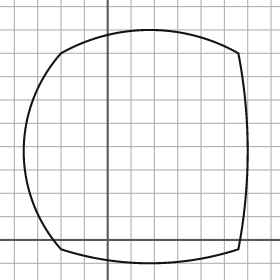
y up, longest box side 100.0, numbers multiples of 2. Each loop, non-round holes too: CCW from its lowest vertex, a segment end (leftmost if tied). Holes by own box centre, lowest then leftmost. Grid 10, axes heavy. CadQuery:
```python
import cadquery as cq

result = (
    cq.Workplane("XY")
    .moveTo(-20.0, -4.0)
    .threePointArc((18.0, -10.0), (56.0, -4.0))
    .threePointArc((60.0, 38.0), (56.0, 80.0))
    .threePointArc((18.0, 90.0), (-20.0, 80.0))
    .threePointArc((-36.0, 38.0), (-20.0, -4.0))
    .close()
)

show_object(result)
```